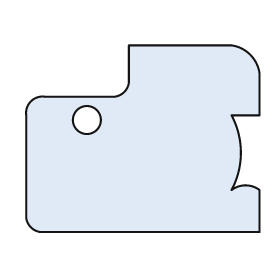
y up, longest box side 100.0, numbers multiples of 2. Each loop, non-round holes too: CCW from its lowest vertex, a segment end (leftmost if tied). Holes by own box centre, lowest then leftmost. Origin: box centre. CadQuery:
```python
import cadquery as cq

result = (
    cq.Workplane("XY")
    .moveTo(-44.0, -40.0)
    .lineTo(50.0, -40.0)
    .lineTo(50.0, -22.0)
    .threePointArc((44.0, -20.0), (38.0, -22.0))
    .threePointArc((42.0, -6.0), (38.0, 10.0))
    .lineTo(50.0, 10.0)
    .lineTo(50.0, 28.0)
    .threePointArc((46.0, 36.0), (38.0, 40.0))
    .lineTo(-6.0, 40.0)
    .lineTo(-6.0, 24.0)
    .threePointArc((-8.0, 20.0), (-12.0, 18.0))
    .lineTo(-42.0, 18.0)
    .threePointArc((-48.0, 16.0), (-50.0, 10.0))
    .lineTo(-50.0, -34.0)
    .threePointArc((-48.0, -38.0), (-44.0, -40.0))
    .close()
    .moveTo(-24.0, 8.0)
    .circle(6.0)
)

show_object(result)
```